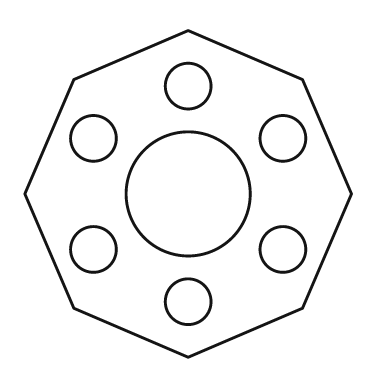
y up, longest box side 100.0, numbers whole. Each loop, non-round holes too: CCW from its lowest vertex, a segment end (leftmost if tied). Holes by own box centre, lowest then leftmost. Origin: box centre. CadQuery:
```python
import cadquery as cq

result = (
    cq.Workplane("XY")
    .moveTo(0.0, -50.0)
    .lineTo(35.0, -35.0)
    .lineTo(50.0, 0.0)
    .lineTo(35.0, 35.0)
    .lineTo(0.0, 50.0)
    .lineTo(-35.0, 35.0)
    .lineTo(-50.0, 0.0)
    .lineTo(-35.0, -35.0)
    .close()
    .moveTo(0.0, -33.0)
    .circle(7.0)
    .moveTo(-29.0, -17.0)
    .circle(7.0)
    .moveTo(29.0, -17.0)
    .circle(7.0)
    .moveTo(0.0, 0.0)
    .circle(19.0)
    .moveTo(-29.0, 17.0)
    .circle(7.0)
    .moveTo(29.0, 17.0)
    .circle(7.0)
    .moveTo(0.0, 33.0)
    .circle(7.0)
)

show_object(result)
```